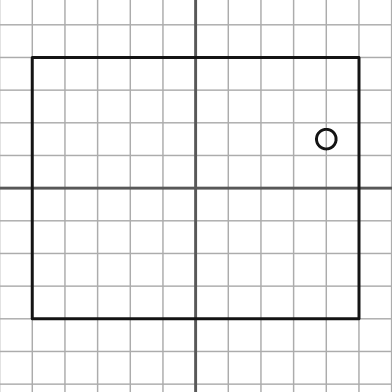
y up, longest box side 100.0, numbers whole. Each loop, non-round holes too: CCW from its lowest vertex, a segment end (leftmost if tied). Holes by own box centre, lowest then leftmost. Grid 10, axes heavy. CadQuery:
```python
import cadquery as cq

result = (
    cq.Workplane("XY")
    .moveTo(-50.0, -40.0)
    .lineTo(50.0, -40.0)
    .lineTo(50.0, 40.0)
    .lineTo(-50.0, 40.0)
    .close()
    .moveTo(40.0, 15.0)
    .circle(3.0)
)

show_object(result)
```